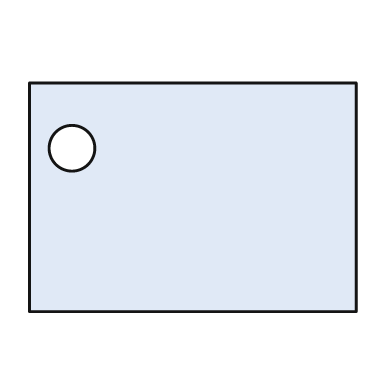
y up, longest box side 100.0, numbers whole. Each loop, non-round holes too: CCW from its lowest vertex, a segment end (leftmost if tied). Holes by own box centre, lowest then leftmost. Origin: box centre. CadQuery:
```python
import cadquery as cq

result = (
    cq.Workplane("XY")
    .moveTo(-50.0, -35.0)
    .lineTo(50.0, -35.0)
    .lineTo(50.0, 35.0)
    .lineTo(-50.0, 35.0)
    .close()
    .moveTo(-37.0, 15.0)
    .circle(7.0)
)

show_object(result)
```